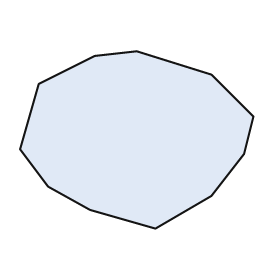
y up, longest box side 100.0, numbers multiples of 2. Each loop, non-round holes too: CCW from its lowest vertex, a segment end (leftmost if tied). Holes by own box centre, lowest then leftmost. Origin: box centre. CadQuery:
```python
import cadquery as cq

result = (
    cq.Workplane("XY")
    .moveTo(8.0, -38.0)
    .lineTo(32.0, -24.0)
    .lineTo(46.0, -6.0)
    .lineTo(50.0, 10.0)
    .lineTo(32.0, 28.0)
    .lineTo(0.0, 38.0)
    .lineTo(-18.0, 36.0)
    .lineTo(-42.0, 24.0)
    .lineTo(-50.0, -4.0)
    .lineTo(-38.0, -20.0)
    .lineTo(-20.0, -30.0)
    .close()
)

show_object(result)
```